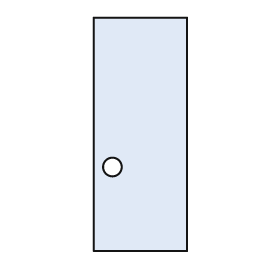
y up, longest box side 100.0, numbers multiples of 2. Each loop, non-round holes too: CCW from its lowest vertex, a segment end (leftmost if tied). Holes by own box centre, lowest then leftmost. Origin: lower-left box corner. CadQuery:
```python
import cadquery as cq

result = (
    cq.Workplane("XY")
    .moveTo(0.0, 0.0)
    .lineTo(40.0, 0.0)
    .lineTo(40.0, 100.0)
    .lineTo(0.0, 100.0)
    .close()
    .moveTo(8.0, 36.0)
    .circle(4.0)
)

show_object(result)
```